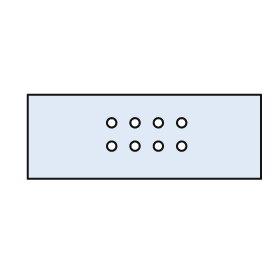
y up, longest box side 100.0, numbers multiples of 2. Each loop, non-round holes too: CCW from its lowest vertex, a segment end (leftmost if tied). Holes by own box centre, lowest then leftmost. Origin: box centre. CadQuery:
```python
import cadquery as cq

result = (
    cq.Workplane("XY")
    .moveTo(-50.0, -18.0)
    .lineTo(50.0, -18.0)
    .lineTo(50.0, 18.0)
    .lineTo(-50.0, 18.0)
    .close()
    .moveTo(-14.0, -4.0)
    .circle(2.0)
    .moveTo(-4.0, -4.0)
    .circle(2.0)
    .moveTo(6.0, -4.0)
    .circle(2.0)
    .moveTo(16.0, -4.0)
    .circle(2.0)
    .moveTo(-14.0, 6.0)
    .circle(2.0)
    .moveTo(-4.0, 6.0)
    .circle(2.0)
    .moveTo(6.0, 6.0)
    .circle(2.0)
    .moveTo(16.0, 6.0)
    .circle(2.0)
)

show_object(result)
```